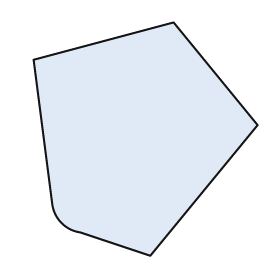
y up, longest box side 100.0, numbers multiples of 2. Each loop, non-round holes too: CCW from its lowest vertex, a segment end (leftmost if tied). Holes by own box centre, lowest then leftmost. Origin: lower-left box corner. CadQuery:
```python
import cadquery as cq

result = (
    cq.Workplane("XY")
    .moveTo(50.0, 0.0)
    .lineTo(96.0, 56.0)
    .lineTo(60.0, 100.0)
    .lineTo(0.0, 84.0)
    .lineTo(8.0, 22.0)
    .threePointArc((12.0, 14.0), (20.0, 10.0))
    .close()
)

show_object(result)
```